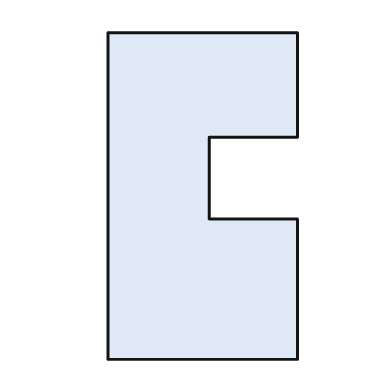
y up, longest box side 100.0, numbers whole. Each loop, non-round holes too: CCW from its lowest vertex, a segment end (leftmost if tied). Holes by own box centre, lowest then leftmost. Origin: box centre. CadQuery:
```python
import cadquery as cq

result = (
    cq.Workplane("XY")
    .moveTo(-29.0, -50.0)
    .lineTo(29.0, -50.0)
    .lineTo(29.0, -7.0)
    .lineTo(2.0, -7.0)
    .lineTo(2.0, 18.0)
    .lineTo(29.0, 18.0)
    .lineTo(29.0, 50.0)
    .lineTo(-29.0, 50.0)
    .close()
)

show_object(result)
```